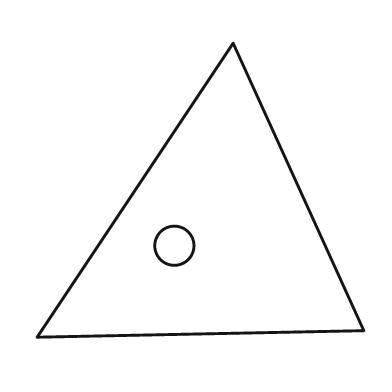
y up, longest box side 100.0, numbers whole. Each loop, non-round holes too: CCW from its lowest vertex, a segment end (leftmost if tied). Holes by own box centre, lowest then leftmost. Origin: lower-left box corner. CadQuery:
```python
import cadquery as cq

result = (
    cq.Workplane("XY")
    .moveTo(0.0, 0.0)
    .lineTo(100.0, 2.0)
    .lineTo(60.0, 90.0)
    .close()
    .moveTo(42.0, 28.0)
    .circle(6.0)
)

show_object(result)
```